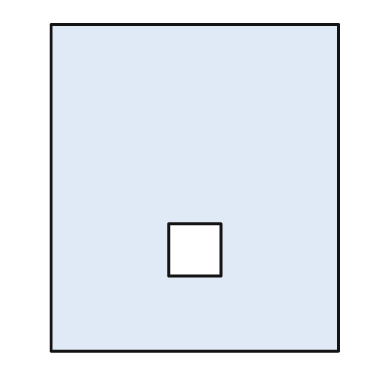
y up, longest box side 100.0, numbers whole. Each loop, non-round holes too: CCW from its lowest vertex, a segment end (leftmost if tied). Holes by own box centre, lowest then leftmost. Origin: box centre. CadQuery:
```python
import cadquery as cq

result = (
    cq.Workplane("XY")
    .moveTo(-44.0, -50.0)
    .lineTo(44.0, -50.0)
    .lineTo(44.0, 50.0)
    .lineTo(-44.0, 50.0)
    .close()
    .moveTo(-8.0, -27.0)
    .lineTo(8.0, -27.0)
    .lineTo(8.0, -11.0)
    .lineTo(-8.0, -11.0)
    .close()
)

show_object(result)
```